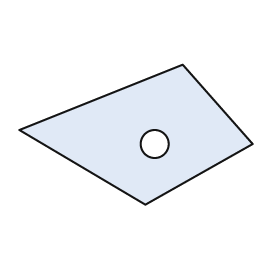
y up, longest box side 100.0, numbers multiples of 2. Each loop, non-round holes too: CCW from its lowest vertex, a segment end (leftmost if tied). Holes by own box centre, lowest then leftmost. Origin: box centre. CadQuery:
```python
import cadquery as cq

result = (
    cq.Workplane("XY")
    .moveTo(4.0, -30.0)
    .lineTo(50.0, -4.0)
    .lineTo(20.0, 30.0)
    .lineTo(-50.0, 2.0)
    .close()
    .moveTo(8.0, -4.0)
    .circle(6.0)
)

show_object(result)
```